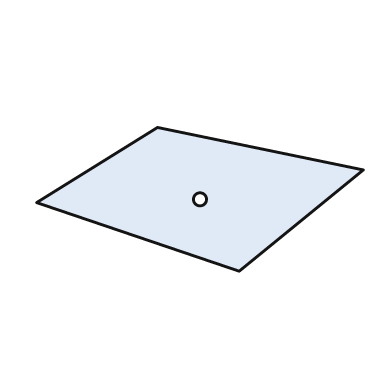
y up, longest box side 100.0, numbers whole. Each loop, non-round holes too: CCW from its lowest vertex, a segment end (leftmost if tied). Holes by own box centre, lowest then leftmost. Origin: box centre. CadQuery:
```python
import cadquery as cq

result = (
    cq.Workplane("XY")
    .moveTo(12.0, -22.0)
    .lineTo(50.0, 9.0)
    .lineTo(-13.0, 22.0)
    .lineTo(-50.0, -1.0)
    .close()
    .moveTo(0.0, 0.0)
    .circle(2.0)
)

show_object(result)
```